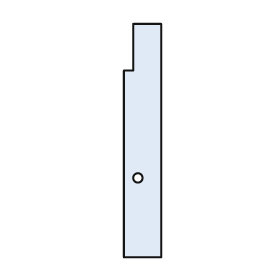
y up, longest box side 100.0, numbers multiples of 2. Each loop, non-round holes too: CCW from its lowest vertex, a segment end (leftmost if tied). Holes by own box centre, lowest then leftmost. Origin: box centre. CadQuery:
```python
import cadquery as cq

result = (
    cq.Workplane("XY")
    .moveTo(-8.0, -50.0)
    .lineTo(8.0, -50.0)
    .lineTo(8.0, 50.0)
    .lineTo(-4.0, 50.0)
    .lineTo(-4.0, 30.0)
    .lineTo(-8.0, 30.0)
    .close()
    .moveTo(-2.0, -16.0)
    .circle(2.0)
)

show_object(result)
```